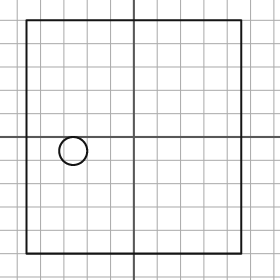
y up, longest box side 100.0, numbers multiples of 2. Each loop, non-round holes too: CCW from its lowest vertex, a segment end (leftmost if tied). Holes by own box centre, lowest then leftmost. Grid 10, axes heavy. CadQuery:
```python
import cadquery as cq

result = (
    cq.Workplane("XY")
    .moveTo(-46.0, -50.0)
    .lineTo(46.0, -50.0)
    .lineTo(46.0, 50.0)
    .lineTo(-46.0, 50.0)
    .close()
    .moveTo(-26.0, -6.0)
    .circle(6.0)
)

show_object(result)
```